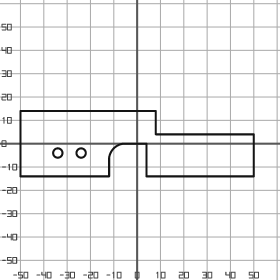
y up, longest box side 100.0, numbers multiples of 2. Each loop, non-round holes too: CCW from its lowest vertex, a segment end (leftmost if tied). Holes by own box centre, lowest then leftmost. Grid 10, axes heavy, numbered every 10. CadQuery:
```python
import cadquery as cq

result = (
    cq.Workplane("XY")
    .moveTo(-50.0, -14.0)
    .lineTo(-12.0, -14.0)
    .lineTo(-12.0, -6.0)
    .threePointArc((-10.0, -2.0), (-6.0, 0.0))
    .lineTo(4.0, 0.0)
    .lineTo(4.0, -14.0)
    .lineTo(50.0, -14.0)
    .lineTo(50.0, 4.0)
    .lineTo(8.0, 4.0)
    .lineTo(8.0, 14.0)
    .lineTo(-50.0, 14.0)
    .close()
    .moveTo(-34.0, -4.0)
    .circle(2.0)
    .moveTo(-24.0, -4.0)
    .circle(2.0)
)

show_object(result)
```